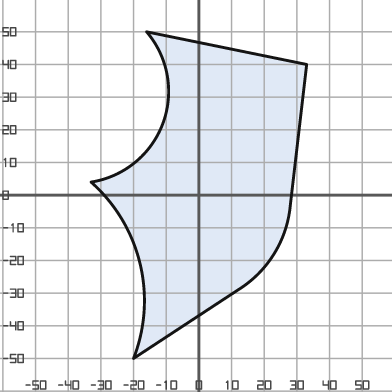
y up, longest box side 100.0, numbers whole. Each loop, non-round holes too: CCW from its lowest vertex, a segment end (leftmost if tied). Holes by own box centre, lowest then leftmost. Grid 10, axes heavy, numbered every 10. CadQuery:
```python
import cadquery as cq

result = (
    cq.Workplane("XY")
    .moveTo(-20.0, -50.0)
    .lineTo(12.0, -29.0)
    .threePointArc((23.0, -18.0), (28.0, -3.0))
    .lineTo(33.0, 40.0)
    .lineTo(-16.0, 50.0)
    .threePointArc((-11.0, 22.0), (-33.0, 4.0))
    .threePointArc((-18.0, -21.0), (-20.0, -50.0))
    .close()
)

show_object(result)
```